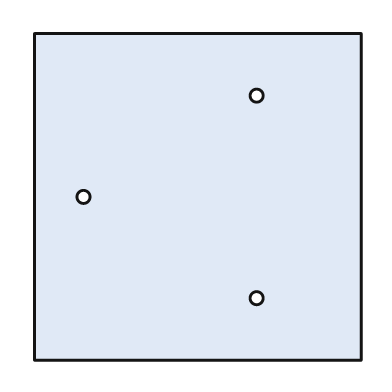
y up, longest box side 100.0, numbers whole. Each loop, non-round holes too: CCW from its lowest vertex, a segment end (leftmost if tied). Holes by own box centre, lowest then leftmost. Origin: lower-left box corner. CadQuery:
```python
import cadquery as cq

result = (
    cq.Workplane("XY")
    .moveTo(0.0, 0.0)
    .lineTo(100.0, 0.0)
    .lineTo(100.0, 100.0)
    .lineTo(0.0, 100.0)
    .close()
    .moveTo(68.0, 19.0)
    .circle(2.0)
    .moveTo(15.0, 50.0)
    .circle(2.0)
    .moveTo(68.0, 81.0)
    .circle(2.0)
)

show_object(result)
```